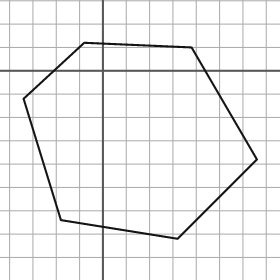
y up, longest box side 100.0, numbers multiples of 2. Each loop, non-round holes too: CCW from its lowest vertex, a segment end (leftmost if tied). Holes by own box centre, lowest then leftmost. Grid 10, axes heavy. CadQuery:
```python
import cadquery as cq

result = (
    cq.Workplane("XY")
    .moveTo(32.0, -72.0)
    .lineTo(66.0, -38.0)
    .lineTo(38.0, 10.0)
    .lineTo(-8.0, 12.0)
    .lineTo(-34.0, -12.0)
    .lineTo(-18.0, -64.0)
    .close()
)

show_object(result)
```